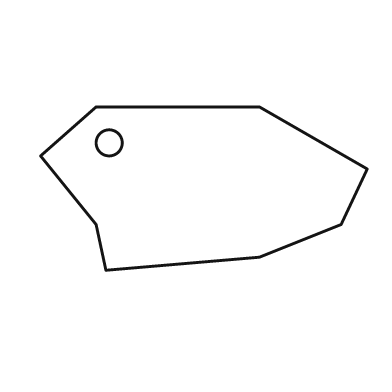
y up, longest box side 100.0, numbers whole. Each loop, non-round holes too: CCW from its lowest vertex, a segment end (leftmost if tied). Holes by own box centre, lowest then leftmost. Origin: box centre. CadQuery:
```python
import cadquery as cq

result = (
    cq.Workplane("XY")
    .moveTo(-30.0, -25.0)
    .lineTo(17.0, -21.0)
    .lineTo(42.0, -11.0)
    .lineTo(50.0, 6.0)
    .lineTo(17.0, 25.0)
    .lineTo(-33.0, 25.0)
    .lineTo(-50.0, 10.0)
    .lineTo(-33.0, -11.0)
    .close()
    .moveTo(-29.0, 14.0)
    .circle(4.0)
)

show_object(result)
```